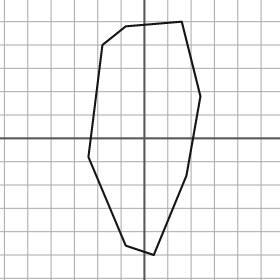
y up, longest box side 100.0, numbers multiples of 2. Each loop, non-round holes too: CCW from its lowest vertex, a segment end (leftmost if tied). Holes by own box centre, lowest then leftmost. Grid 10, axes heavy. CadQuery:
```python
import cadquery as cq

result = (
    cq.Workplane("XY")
    .moveTo(4.0, -50.0)
    .lineTo(18.0, -16.0)
    .lineTo(24.0, 18.0)
    .lineTo(16.0, 50.0)
    .lineTo(-8.0, 48.0)
    .lineTo(-18.0, 40.0)
    .lineTo(-24.0, -8.0)
    .lineTo(-8.0, -46.0)
    .close()
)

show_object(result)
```